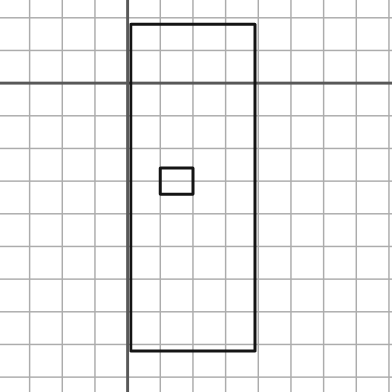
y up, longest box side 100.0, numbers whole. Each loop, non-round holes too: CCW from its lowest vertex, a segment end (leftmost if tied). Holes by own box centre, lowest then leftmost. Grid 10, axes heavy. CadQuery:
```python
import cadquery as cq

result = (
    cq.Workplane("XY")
    .moveTo(1.0, -82.0)
    .lineTo(39.0, -82.0)
    .lineTo(39.0, 18.0)
    .lineTo(1.0, 18.0)
    .close()
    .moveTo(10.0, -34.0)
    .lineTo(20.0, -34.0)
    .lineTo(20.0, -26.0)
    .lineTo(10.0, -26.0)
    .close()
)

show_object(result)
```